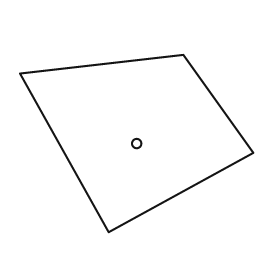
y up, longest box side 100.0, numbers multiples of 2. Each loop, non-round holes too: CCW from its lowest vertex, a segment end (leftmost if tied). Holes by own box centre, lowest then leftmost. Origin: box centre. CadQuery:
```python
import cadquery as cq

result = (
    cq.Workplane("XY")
    .moveTo(-12.0, -38.0)
    .lineTo(50.0, -4.0)
    .lineTo(20.0, 38.0)
    .lineTo(-50.0, 30.0)
    .close()
    .moveTo(0.0, 0.0)
    .circle(2.0)
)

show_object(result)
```